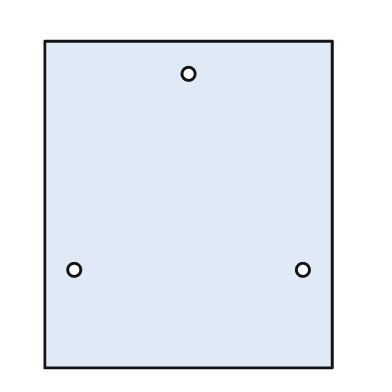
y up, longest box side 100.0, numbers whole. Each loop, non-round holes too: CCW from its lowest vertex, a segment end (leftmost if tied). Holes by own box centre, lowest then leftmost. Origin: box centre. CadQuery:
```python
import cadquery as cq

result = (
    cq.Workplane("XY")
    .moveTo(-44.0, -50.0)
    .lineTo(44.0, -50.0)
    .lineTo(44.0, 50.0)
    .lineTo(-44.0, 50.0)
    .close()
    .moveTo(-35.0, -20.0)
    .circle(2.0)
    .moveTo(35.0, -20.0)
    .circle(2.0)
    .moveTo(0.0, 40.0)
    .circle(2.0)
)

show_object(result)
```